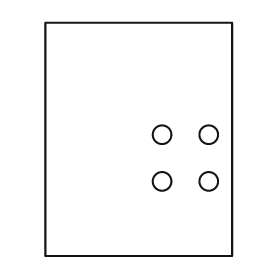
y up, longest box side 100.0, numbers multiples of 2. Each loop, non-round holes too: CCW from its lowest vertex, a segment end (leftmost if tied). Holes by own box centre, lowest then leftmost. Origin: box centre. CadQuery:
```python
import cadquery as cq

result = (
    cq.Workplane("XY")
    .moveTo(-40.0, -50.0)
    .lineTo(40.0, -50.0)
    .lineTo(40.0, 50.0)
    .lineTo(-40.0, 50.0)
    .close()
    .moveTo(10.0, -18.0)
    .circle(4.0)
    .moveTo(30.0, -18.0)
    .circle(4.0)
    .moveTo(10.0, 2.0)
    .circle(4.0)
    .moveTo(30.0, 2.0)
    .circle(4.0)
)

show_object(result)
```